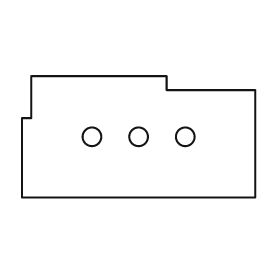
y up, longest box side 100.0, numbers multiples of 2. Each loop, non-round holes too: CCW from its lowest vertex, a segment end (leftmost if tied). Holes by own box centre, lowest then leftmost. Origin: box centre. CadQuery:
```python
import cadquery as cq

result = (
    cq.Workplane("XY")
    .moveTo(-50.0, -26.0)
    .lineTo(50.0, -26.0)
    .lineTo(50.0, 20.0)
    .lineTo(12.0, 20.0)
    .lineTo(12.0, 26.0)
    .lineTo(-46.0, 26.0)
    .lineTo(-46.0, 8.0)
    .lineTo(-50.0, 8.0)
    .close()
    .moveTo(-20.0, 0.0)
    .circle(4.0)
    .moveTo(0.0, 0.0)
    .circle(4.0)
    .moveTo(20.0, 0.0)
    .circle(4.0)
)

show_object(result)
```